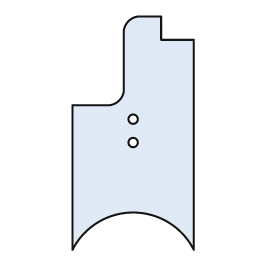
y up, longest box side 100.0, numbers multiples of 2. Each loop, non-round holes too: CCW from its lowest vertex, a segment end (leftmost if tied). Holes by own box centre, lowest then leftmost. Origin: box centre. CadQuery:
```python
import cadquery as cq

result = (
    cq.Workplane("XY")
    .moveTo(-26.0, -50.0)
    .threePointArc((0.0, -34.0), (26.0, -50.0))
    .lineTo(26.0, 40.0)
    .lineTo(12.0, 40.0)
    .lineTo(12.0, 50.0)
    .lineTo(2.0, 50.0)
    .threePointArc((-2.0, 48.0), (-4.0, 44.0))
    .lineTo(-4.0, 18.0)
    .threePointArc((-6.0, 14.0), (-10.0, 12.0))
    .lineTo(-26.0, 12.0)
    .close()
    .moveTo(0.0, -4.0)
    .circle(2.0)
    .moveTo(0.0, 6.0)
    .circle(2.0)
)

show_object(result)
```